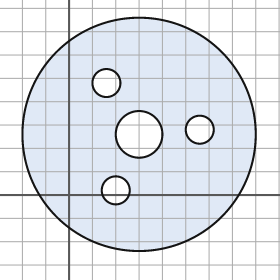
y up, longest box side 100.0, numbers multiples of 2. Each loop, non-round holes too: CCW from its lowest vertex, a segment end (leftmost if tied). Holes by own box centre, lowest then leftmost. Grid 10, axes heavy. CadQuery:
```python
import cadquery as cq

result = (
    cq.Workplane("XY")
    .moveTo(30.0, 26.0)
    .circle(50.0)
    .moveTo(20.0, 2.0)
    .circle(6.0)
    .moveTo(30.0, 26.0)
    .circle(10.0)
    .moveTo(56.0, 28.0)
    .circle(6.0)
    .moveTo(16.0, 48.0)
    .circle(6.0)
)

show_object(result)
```